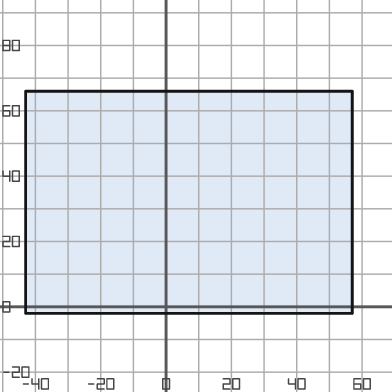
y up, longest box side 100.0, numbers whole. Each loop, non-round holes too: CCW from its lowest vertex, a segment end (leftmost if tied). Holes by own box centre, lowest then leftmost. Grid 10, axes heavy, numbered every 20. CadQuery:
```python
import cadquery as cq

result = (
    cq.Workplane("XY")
    .moveTo(-43.0, -2.0)
    .lineTo(57.0, -2.0)
    .lineTo(57.0, 66.0)
    .lineTo(-43.0, 66.0)
    .close()
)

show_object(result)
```